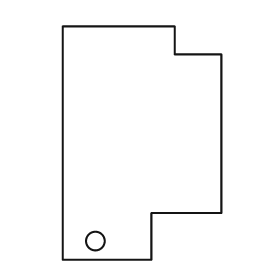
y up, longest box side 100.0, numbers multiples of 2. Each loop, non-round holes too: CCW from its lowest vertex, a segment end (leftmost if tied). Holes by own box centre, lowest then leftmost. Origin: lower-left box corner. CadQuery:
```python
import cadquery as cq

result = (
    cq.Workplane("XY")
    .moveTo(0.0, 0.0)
    .lineTo(38.0, 0.0)
    .lineTo(38.0, 20.0)
    .lineTo(68.0, 20.0)
    .lineTo(68.0, 88.0)
    .lineTo(48.0, 88.0)
    .lineTo(48.0, 100.0)
    .lineTo(0.0, 100.0)
    .close()
    .moveTo(14.0, 8.0)
    .circle(4.0)
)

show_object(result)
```